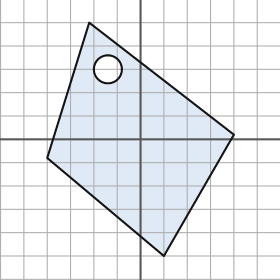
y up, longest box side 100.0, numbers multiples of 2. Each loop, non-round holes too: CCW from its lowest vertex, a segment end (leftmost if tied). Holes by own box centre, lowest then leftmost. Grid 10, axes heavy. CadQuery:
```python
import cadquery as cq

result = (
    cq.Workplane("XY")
    .moveTo(10.0, -50.0)
    .lineTo(40.0, 2.0)
    .lineTo(-22.0, 50.0)
    .lineTo(-40.0, -8.0)
    .close()
    .moveTo(-14.0, 30.0)
    .circle(6.0)
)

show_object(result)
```